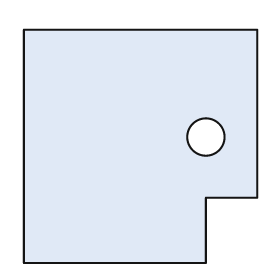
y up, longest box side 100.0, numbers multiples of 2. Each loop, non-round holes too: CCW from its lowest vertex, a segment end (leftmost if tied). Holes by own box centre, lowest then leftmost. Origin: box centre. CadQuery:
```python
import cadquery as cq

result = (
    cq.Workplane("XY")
    .moveTo(-50.0, -50.0)
    .lineTo(28.0, -50.0)
    .lineTo(28.0, -22.0)
    .lineTo(50.0, -22.0)
    .lineTo(50.0, 50.0)
    .lineTo(-50.0, 50.0)
    .close()
    .moveTo(28.0, 4.0)
    .circle(8.0)
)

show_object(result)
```